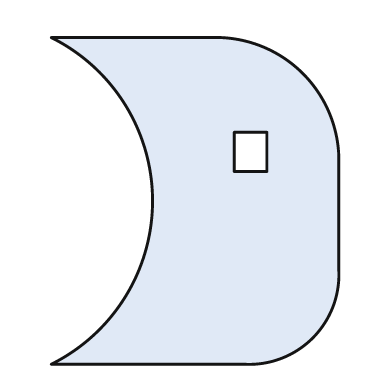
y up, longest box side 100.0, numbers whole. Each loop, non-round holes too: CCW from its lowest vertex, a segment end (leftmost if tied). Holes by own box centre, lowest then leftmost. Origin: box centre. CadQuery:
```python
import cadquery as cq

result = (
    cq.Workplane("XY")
    .moveTo(-44.0, -50.0)
    .lineTo(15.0, -50.0)
    .threePointArc((36.0, -42.0), (44.0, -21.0))
    .lineTo(44.0, 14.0)
    .threePointArc((33.0, 39.0), (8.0, 50.0))
    .lineTo(-44.0, 50.0)
    .threePointArc((-13.0, 0.0), (-44.0, -50.0))
    .close()
    .moveTo(12.0, 9.0)
    .lineTo(22.0, 9.0)
    .lineTo(22.0, 21.0)
    .lineTo(12.0, 21.0)
    .close()
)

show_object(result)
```